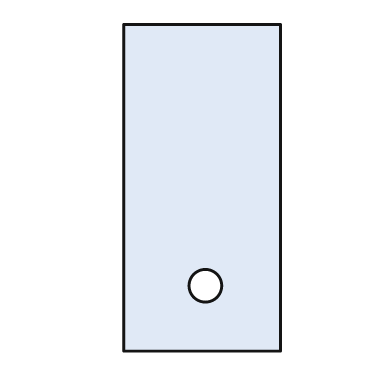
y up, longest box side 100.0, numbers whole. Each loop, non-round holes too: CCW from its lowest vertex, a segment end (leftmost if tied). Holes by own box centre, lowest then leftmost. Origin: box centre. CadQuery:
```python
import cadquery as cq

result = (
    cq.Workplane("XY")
    .moveTo(-24.0, -50.0)
    .lineTo(24.0, -50.0)
    .lineTo(24.0, 50.0)
    .lineTo(-24.0, 50.0)
    .close()
    .moveTo(1.0, -30.0)
    .circle(5.0)
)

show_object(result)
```